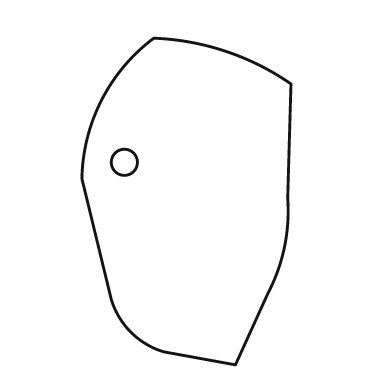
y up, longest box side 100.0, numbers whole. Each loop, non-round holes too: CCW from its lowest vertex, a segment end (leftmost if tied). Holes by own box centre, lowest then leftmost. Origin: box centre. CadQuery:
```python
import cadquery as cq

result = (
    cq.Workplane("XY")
    .moveTo(15.0, -50.0)
    .lineTo(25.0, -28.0)
    .threePointArc((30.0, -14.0), (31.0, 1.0))
    .lineTo(32.0, 36.0)
    .threePointArc((12.0, 46.0), (-10.0, 50.0))
    .threePointArc((-26.0, 31.0), (-32.0, 7.0))
    .lineTo(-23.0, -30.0)
    .threePointArc((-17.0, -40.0), (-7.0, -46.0))
    .close()
    .moveTo(-19.0, 12.0)
    .circle(4.0)
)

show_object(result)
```